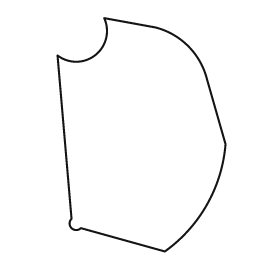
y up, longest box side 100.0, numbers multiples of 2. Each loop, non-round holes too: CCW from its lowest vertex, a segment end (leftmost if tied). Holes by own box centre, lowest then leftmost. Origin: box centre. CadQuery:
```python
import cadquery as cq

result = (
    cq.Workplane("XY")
    .moveTo(10.0, -50.0)
    .threePointArc((28.0, -30.0), (36.0, -4.0))
    .lineTo(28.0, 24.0)
    .threePointArc((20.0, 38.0), (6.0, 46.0))
    .lineTo(-16.0, 50.0)
    .threePointArc((-20.0, 34.0), (-36.0, 34.0))
    .lineTo(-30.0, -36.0)
    .threePointArc((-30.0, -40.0), (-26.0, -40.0))
    .close()
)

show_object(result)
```